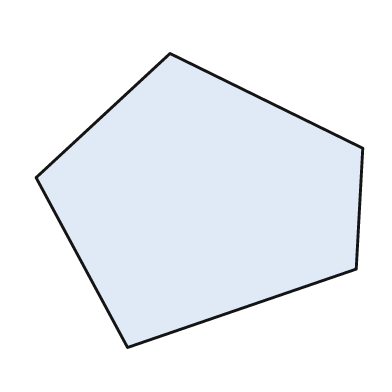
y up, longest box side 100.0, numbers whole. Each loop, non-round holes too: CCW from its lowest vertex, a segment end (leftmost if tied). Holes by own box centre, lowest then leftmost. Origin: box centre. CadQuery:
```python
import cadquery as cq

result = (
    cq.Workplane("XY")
    .moveTo(-22.0, -45.0)
    .lineTo(48.0, -21.0)
    .lineTo(50.0, 16.0)
    .lineTo(-9.0, 45.0)
    .lineTo(-50.0, 7.0)
    .close()
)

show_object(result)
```